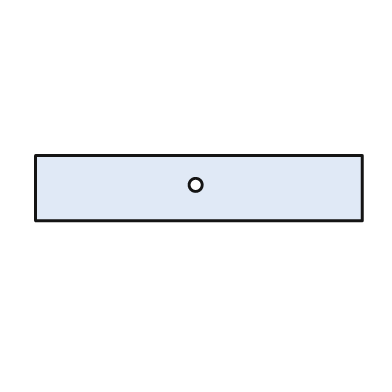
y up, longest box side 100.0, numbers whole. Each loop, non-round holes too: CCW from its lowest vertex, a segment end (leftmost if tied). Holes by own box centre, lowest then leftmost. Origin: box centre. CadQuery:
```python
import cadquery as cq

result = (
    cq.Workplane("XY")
    .moveTo(-50.0, -10.0)
    .lineTo(50.0, -10.0)
    .lineTo(50.0, 10.0)
    .lineTo(-50.0, 10.0)
    .close()
    .moveTo(-1.0, 1.0)
    .circle(2.0)
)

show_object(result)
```